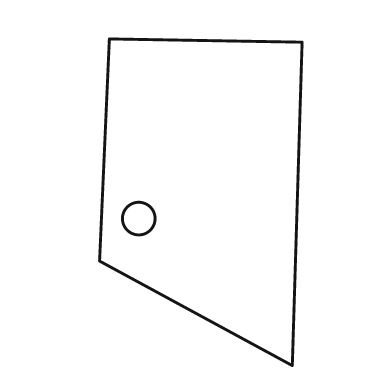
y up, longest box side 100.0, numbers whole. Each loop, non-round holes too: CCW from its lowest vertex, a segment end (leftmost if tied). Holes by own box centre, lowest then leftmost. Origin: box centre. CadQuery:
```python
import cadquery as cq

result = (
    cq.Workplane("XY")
    .moveTo(28.0, -50.0)
    .lineTo(31.0, 49.0)
    .lineTo(-28.0, 50.0)
    .lineTo(-31.0, -18.0)
    .close()
    .moveTo(-19.0, -5.0)
    .circle(5.0)
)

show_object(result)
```